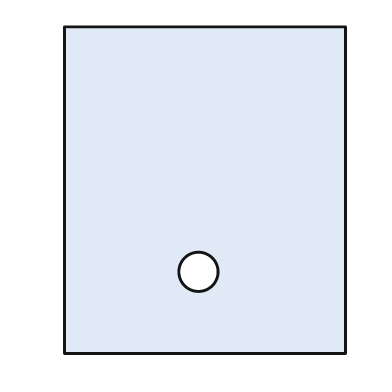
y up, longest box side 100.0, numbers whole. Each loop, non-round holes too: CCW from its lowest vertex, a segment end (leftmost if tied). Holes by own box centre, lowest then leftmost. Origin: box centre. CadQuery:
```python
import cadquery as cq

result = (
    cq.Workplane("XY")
    .moveTo(-43.0, -50.0)
    .lineTo(43.0, -50.0)
    .lineTo(43.0, 50.0)
    .lineTo(-43.0, 50.0)
    .close()
    .moveTo(-2.0, -25.0)
    .circle(6.0)
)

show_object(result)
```